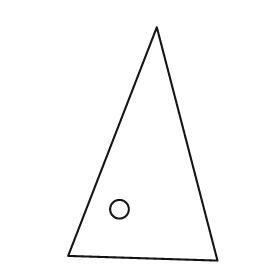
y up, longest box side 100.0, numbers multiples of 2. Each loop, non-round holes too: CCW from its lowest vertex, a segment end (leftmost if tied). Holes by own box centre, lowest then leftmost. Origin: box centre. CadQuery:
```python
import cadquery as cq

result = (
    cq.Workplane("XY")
    .moveTo(32.0, -50.0)
    .lineTo(6.0, 50.0)
    .lineTo(-32.0, -48.0)
    .close()
    .moveTo(-10.0, -28.0)
    .circle(4.0)
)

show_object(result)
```